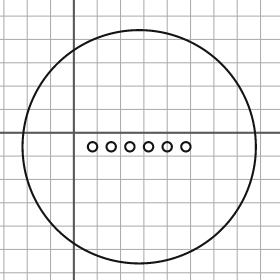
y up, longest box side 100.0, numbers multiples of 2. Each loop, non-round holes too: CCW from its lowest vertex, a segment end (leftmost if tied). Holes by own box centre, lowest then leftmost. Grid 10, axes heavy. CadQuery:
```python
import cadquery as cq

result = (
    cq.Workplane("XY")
    .moveTo(28.0, -6.0)
    .circle(50.0)
    .moveTo(8.0, -6.0)
    .circle(2.0)
    .moveTo(16.0, -6.0)
    .circle(2.0)
    .moveTo(24.0, -6.0)
    .circle(2.0)
    .moveTo(32.0, -6.0)
    .circle(2.0)
    .moveTo(40.0, -6.0)
    .circle(2.0)
    .moveTo(48.0, -6.0)
    .circle(2.0)
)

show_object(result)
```